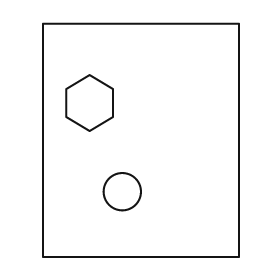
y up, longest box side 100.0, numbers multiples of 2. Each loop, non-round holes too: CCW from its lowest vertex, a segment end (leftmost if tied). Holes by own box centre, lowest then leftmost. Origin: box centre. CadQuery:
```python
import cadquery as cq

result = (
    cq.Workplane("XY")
    .moveTo(-42.0, -50.0)
    .lineTo(42.0, -50.0)
    .lineTo(42.0, 50.0)
    .lineTo(-42.0, 50.0)
    .close()
    .moveTo(-8.0, -22.0)
    .circle(8.0)
    .moveTo(-22.0, 4.0)
    .lineTo(-12.0, 10.0)
    .lineTo(-12.0, 22.0)
    .lineTo(-22.0, 28.0)
    .lineTo(-32.0, 22.0)
    .lineTo(-32.0, 10.0)
    .close()
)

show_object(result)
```